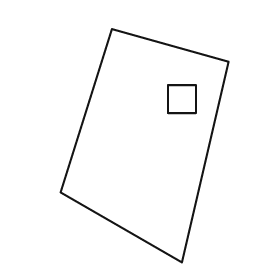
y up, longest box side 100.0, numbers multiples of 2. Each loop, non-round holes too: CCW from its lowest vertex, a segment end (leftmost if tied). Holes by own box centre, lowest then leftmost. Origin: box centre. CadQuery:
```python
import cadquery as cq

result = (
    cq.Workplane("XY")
    .moveTo(16.0, -50.0)
    .lineTo(36.0, 36.0)
    .lineTo(-14.0, 50.0)
    .lineTo(-36.0, -20.0)
    .close()
    .moveTo(10.0, 14.0)
    .lineTo(22.0, 14.0)
    .lineTo(22.0, 26.0)
    .lineTo(10.0, 26.0)
    .close()
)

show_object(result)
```